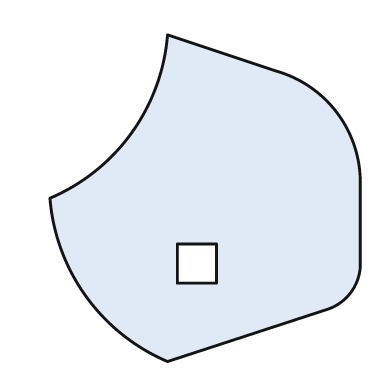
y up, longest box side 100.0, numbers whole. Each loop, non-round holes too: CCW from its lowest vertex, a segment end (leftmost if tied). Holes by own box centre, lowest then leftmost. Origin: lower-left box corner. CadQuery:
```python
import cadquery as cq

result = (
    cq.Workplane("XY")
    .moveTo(36.0, 0.0)
    .lineTo(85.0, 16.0)
    .threePointArc((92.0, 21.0), (95.0, 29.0))
    .lineTo(95.0, 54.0)
    .threePointArc((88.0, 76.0), (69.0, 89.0))
    .lineTo(36.0, 100.0)
    .threePointArc((25.0, 70.0), (0.0, 50.0))
    .threePointArc((11.0, 20.0), (36.0, 0.0))
    .close()
    .moveTo(39.0, 24.0)
    .lineTo(51.0, 24.0)
    .lineTo(51.0, 36.0)
    .lineTo(39.0, 36.0)
    .close()
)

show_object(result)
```